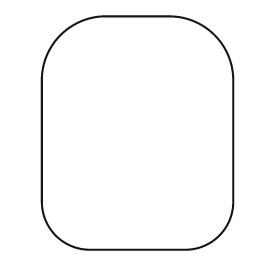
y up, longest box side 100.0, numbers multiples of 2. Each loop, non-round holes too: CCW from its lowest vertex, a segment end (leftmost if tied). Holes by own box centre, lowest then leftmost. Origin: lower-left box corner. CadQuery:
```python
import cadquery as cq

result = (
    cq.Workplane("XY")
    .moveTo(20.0, 0.0)
    .lineTo(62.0, 0.0)
    .threePointArc((76.0, 6.0), (82.0, 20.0))
    .lineTo(82.0, 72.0)
    .threePointArc((74.0, 92.0), (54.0, 100.0))
    .lineTo(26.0, 100.0)
    .threePointArc((8.0, 92.0), (0.0, 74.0))
    .lineTo(0.0, 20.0)
    .threePointArc((6.0, 6.0), (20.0, 0.0))
    .close()
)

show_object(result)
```